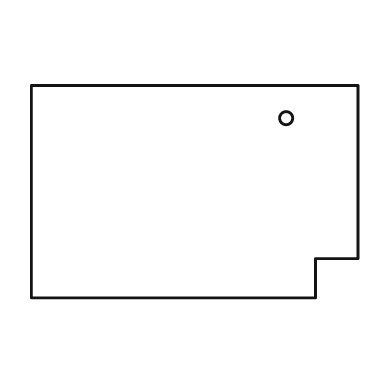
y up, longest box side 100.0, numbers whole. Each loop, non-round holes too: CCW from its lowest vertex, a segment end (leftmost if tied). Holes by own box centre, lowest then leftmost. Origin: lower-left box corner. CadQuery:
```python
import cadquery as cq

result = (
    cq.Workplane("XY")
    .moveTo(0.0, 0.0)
    .lineTo(87.0, 0.0)
    .lineTo(87.0, 12.0)
    .lineTo(100.0, 12.0)
    .lineTo(100.0, 65.0)
    .lineTo(0.0, 65.0)
    .close()
    .moveTo(78.0, 55.0)
    .circle(2.0)
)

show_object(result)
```